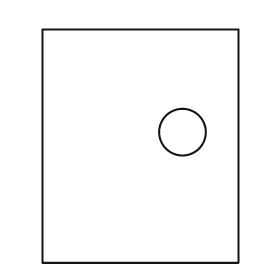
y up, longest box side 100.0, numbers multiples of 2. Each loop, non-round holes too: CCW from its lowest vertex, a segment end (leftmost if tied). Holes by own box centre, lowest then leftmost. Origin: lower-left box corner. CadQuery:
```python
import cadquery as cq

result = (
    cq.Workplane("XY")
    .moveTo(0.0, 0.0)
    .lineTo(84.0, 0.0)
    .lineTo(84.0, 100.0)
    .lineTo(0.0, 100.0)
    .close()
    .moveTo(60.0, 56.0)
    .circle(10.0)
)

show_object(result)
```